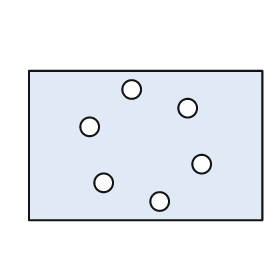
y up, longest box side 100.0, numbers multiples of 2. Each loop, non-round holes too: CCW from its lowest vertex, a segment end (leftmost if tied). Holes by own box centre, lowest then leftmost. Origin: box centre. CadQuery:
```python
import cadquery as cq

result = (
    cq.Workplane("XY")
    .moveTo(-50.0, -32.0)
    .lineTo(50.0, -32.0)
    .lineTo(50.0, 32.0)
    .lineTo(-50.0, 32.0)
    .close()
    .moveTo(6.0, -24.0)
    .circle(4.0)
    .moveTo(-18.0, -16.0)
    .circle(4.0)
    .moveTo(24.0, -8.0)
    .circle(4.0)
    .moveTo(-24.0, 8.0)
    .circle(4.0)
    .moveTo(18.0, 16.0)
    .circle(4.0)
    .moveTo(-6.0, 24.0)
    .circle(4.0)
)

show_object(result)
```